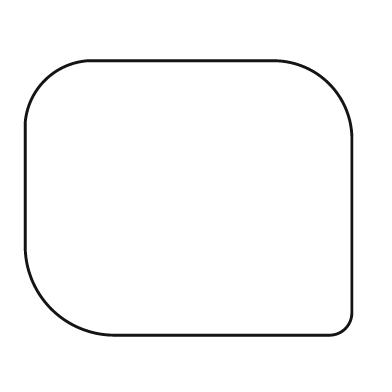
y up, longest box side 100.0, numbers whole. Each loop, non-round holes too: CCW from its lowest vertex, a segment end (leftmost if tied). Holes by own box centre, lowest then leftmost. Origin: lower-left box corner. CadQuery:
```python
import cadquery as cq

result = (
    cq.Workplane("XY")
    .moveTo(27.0, 0.0)
    .lineTo(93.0, 0.0)
    .threePointArc((98.0, 2.0), (100.0, 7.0))
    .lineTo(100.0, 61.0)
    .threePointArc((93.0, 77.0), (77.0, 84.0))
    .lineTo(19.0, 84.0)
    .threePointArc((6.0, 78.0), (0.0, 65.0))
    .lineTo(0.0, 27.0)
    .threePointArc((8.0, 8.0), (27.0, 0.0))
    .close()
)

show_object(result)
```